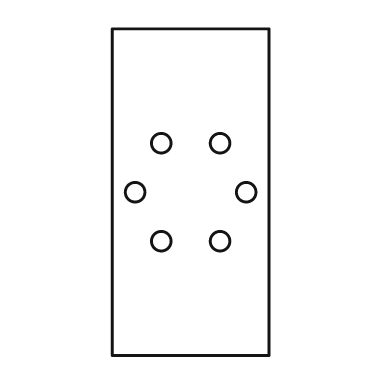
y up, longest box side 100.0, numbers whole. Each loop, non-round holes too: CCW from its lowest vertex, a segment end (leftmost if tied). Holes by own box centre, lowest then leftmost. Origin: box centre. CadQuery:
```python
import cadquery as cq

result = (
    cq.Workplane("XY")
    .moveTo(-24.0, -50.0)
    .lineTo(24.0, -50.0)
    .lineTo(24.0, 50.0)
    .lineTo(-24.0, 50.0)
    .close()
    .moveTo(-9.0, -15.0)
    .circle(3.0)
    .moveTo(9.0, -15.0)
    .circle(3.0)
    .moveTo(-17.0, 0.0)
    .circle(3.0)
    .moveTo(17.0, 0.0)
    .circle(3.0)
    .moveTo(-9.0, 15.0)
    .circle(3.0)
    .moveTo(9.0, 15.0)
    .circle(3.0)
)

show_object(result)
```